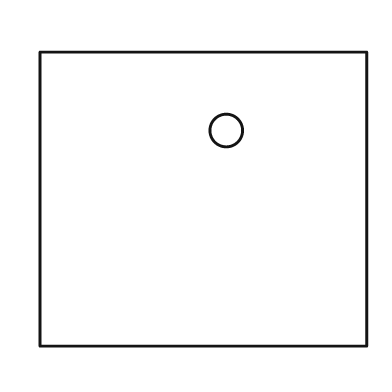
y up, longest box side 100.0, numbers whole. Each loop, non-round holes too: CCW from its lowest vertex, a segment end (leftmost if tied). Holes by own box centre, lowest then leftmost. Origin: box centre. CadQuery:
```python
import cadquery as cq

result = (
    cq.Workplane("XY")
    .moveTo(-50.0, -45.0)
    .lineTo(50.0, -45.0)
    .lineTo(50.0, 45.0)
    .lineTo(-50.0, 45.0)
    .close()
    .moveTo(7.0, 21.0)
    .circle(5.0)
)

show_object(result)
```